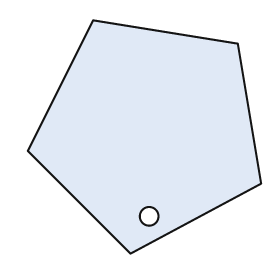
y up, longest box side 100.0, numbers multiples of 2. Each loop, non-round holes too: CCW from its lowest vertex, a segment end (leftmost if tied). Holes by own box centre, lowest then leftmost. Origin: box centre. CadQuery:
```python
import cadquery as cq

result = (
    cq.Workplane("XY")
    .moveTo(-6.0, -50.0)
    .lineTo(50.0, -20.0)
    .lineTo(40.0, 40.0)
    .lineTo(-22.0, 50.0)
    .lineTo(-50.0, -6.0)
    .close()
    .moveTo(2.0, -34.0)
    .circle(4.0)
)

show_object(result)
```